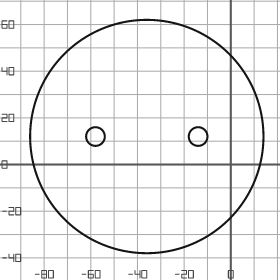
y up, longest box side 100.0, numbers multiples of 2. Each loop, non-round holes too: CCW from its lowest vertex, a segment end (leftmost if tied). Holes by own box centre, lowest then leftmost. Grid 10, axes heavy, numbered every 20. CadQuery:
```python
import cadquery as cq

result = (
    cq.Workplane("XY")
    .moveTo(-36.0, 12.0)
    .circle(50.0)
    .moveTo(-58.0, 12.0)
    .circle(4.0)
    .moveTo(-14.0, 12.0)
    .circle(4.0)
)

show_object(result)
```